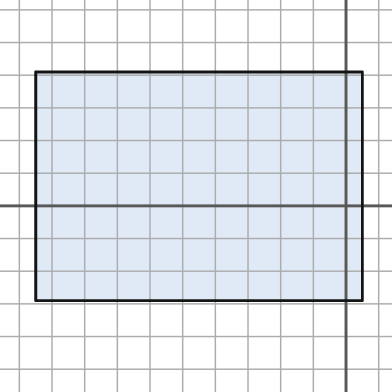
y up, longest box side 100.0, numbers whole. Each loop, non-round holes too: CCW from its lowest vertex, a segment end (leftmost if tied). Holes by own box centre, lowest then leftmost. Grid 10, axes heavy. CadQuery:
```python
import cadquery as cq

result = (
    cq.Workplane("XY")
    .moveTo(-95.0, -29.0)
    .lineTo(5.0, -29.0)
    .lineTo(5.0, 41.0)
    .lineTo(-95.0, 41.0)
    .close()
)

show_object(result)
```